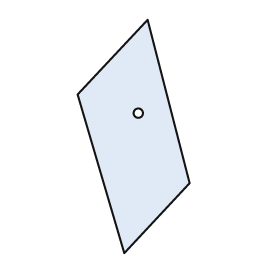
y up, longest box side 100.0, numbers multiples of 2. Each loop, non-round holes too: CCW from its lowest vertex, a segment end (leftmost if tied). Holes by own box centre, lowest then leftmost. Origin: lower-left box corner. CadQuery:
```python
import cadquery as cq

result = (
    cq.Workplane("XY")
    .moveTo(20.0, 0.0)
    .lineTo(48.0, 30.0)
    .lineTo(30.0, 100.0)
    .lineTo(0.0, 68.0)
    .close()
    .moveTo(26.0, 60.0)
    .circle(2.0)
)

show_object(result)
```